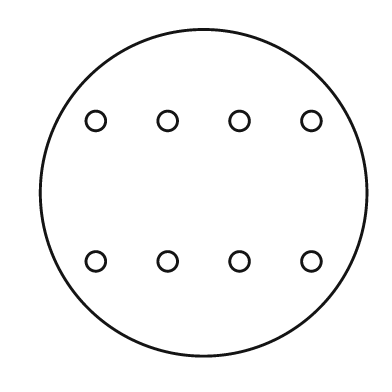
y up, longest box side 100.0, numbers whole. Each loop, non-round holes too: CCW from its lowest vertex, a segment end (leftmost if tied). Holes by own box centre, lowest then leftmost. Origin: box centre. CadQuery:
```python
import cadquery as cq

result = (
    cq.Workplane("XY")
    .moveTo(0.0, 0.0)
    .circle(50.0)
    .moveTo(-33.0, -21.0)
    .circle(3.0)
    .moveTo(-11.0, -21.0)
    .circle(3.0)
    .moveTo(11.0, -21.0)
    .circle(3.0)
    .moveTo(33.0, -21.0)
    .circle(3.0)
    .moveTo(-33.0, 22.0)
    .circle(3.0)
    .moveTo(-11.0, 22.0)
    .circle(3.0)
    .moveTo(11.0, 22.0)
    .circle(3.0)
    .moveTo(33.0, 22.0)
    .circle(3.0)
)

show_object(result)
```